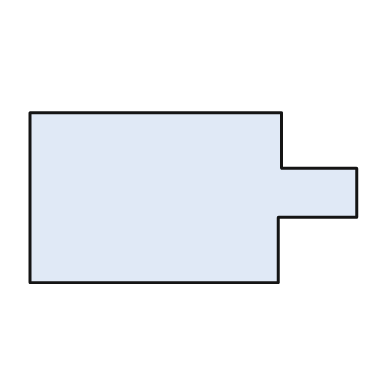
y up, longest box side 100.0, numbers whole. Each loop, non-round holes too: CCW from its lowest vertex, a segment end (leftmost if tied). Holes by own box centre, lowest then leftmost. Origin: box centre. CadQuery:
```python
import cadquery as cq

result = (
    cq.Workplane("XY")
    .moveTo(-50.0, -26.0)
    .lineTo(26.0, -26.0)
    .lineTo(26.0, -6.0)
    .lineTo(50.0, -6.0)
    .lineTo(50.0, 9.0)
    .lineTo(27.0, 9.0)
    .lineTo(27.0, 26.0)
    .lineTo(-50.0, 26.0)
    .close()
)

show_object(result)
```